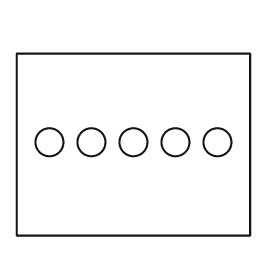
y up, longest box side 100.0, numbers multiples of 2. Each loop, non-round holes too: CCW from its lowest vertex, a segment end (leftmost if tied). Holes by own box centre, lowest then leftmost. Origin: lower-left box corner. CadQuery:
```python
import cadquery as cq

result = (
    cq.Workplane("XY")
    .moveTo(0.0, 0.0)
    .lineTo(100.0, 0.0)
    .lineTo(100.0, 78.0)
    .lineTo(0.0, 78.0)
    .close()
    .moveTo(14.0, 40.0)
    .circle(6.0)
    .moveTo(32.0, 40.0)
    .circle(6.0)
    .moveTo(50.0, 40.0)
    .circle(6.0)
    .moveTo(68.0, 40.0)
    .circle(6.0)
    .moveTo(86.0, 40.0)
    .circle(6.0)
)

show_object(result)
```